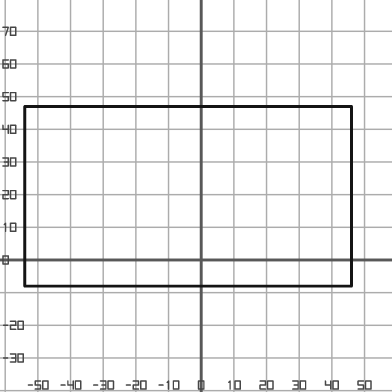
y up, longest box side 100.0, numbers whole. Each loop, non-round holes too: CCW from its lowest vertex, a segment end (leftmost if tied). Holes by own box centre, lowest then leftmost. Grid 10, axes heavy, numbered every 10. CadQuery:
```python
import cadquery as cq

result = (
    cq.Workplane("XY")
    .moveTo(-54.0, -8.0)
    .lineTo(46.0, -8.0)
    .lineTo(46.0, 47.0)
    .lineTo(-54.0, 47.0)
    .close()
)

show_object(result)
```